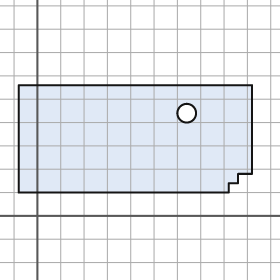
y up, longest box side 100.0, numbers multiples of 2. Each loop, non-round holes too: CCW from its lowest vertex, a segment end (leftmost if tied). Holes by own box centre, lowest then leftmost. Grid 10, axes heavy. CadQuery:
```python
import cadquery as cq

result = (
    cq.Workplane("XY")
    .moveTo(-8.0, 10.0)
    .lineTo(82.0, 10.0)
    .lineTo(82.0, 14.0)
    .lineTo(86.0, 14.0)
    .lineTo(86.0, 18.0)
    .lineTo(92.0, 18.0)
    .lineTo(92.0, 56.0)
    .lineTo(-8.0, 56.0)
    .close()
    .moveTo(64.0, 44.0)
    .circle(4.0)
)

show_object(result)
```